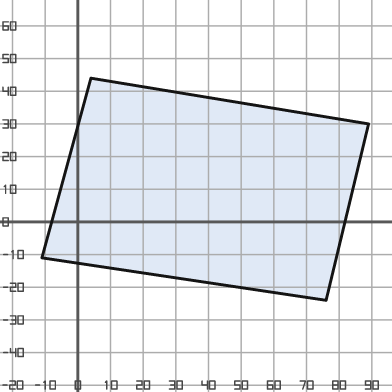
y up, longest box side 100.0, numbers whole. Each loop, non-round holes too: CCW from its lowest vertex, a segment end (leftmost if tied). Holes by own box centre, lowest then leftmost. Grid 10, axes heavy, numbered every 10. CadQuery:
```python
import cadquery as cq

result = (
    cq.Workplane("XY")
    .moveTo(76.0, -24.0)
    .lineTo(89.0, 30.0)
    .lineTo(4.0, 44.0)
    .lineTo(-11.0, -11.0)
    .close()
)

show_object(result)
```